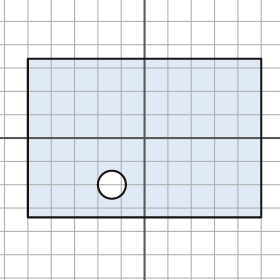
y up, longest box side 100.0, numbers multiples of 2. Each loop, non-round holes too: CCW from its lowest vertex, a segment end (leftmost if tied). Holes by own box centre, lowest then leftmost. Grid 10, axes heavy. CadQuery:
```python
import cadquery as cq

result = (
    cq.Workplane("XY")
    .moveTo(-50.0, -34.0)
    .lineTo(50.0, -34.0)
    .lineTo(50.0, 34.0)
    .lineTo(-50.0, 34.0)
    .close()
    .moveTo(-14.0, -20.0)
    .circle(6.0)
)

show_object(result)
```